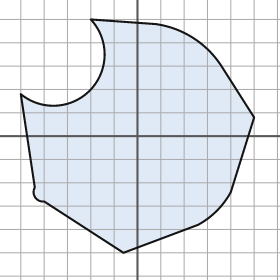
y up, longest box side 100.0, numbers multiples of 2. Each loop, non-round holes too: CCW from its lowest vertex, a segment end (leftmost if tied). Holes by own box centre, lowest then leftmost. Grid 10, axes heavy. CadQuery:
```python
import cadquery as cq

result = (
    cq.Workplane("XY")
    .moveTo(-6.0, -50.0)
    .lineTo(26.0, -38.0)
    .threePointArc((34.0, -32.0), (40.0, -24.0))
    .lineTo(50.0, 8.0)
    .lineTo(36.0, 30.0)
    .threePointArc((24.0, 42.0), (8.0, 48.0))
    .lineTo(-20.0, 50.0)
    .threePointArc((-20.0, 20.0), (-50.0, 18.0))
    .lineTo(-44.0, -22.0)
    .threePointArc((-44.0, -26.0), (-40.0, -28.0))
    .close()
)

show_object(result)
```